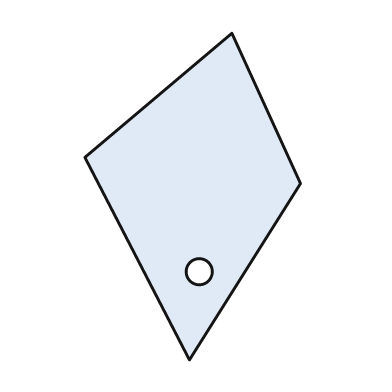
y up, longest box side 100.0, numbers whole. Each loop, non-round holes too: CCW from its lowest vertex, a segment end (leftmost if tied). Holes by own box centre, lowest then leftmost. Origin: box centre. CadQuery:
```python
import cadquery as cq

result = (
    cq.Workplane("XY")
    .moveTo(-1.0, -50.0)
    .lineTo(33.0, 4.0)
    .lineTo(12.0, 50.0)
    .lineTo(-33.0, 12.0)
    .close()
    .moveTo(2.0, -23.0)
    .circle(4.0)
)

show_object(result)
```